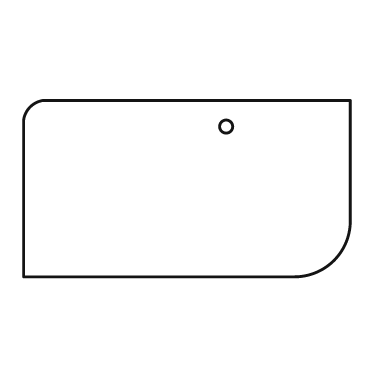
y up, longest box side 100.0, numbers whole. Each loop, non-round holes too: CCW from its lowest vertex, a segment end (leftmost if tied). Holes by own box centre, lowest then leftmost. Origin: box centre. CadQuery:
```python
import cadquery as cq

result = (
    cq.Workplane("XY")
    .moveTo(-50.0, -27.0)
    .lineTo(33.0, -27.0)
    .threePointArc((45.0, -22.0), (50.0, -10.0))
    .lineTo(50.0, 27.0)
    .lineTo(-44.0, 27.0)
    .threePointArc((-48.0, 25.0), (-50.0, 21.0))
    .close()
    .moveTo(12.0, 19.0)
    .circle(2.0)
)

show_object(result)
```